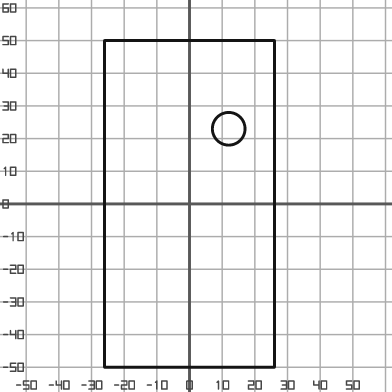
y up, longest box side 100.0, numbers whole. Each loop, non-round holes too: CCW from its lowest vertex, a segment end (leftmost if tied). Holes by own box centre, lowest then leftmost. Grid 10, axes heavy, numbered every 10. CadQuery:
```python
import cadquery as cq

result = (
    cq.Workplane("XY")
    .moveTo(-26.0, -50.0)
    .lineTo(26.0, -50.0)
    .lineTo(26.0, 50.0)
    .lineTo(-26.0, 50.0)
    .close()
    .moveTo(12.0, 23.0)
    .circle(5.0)
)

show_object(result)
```